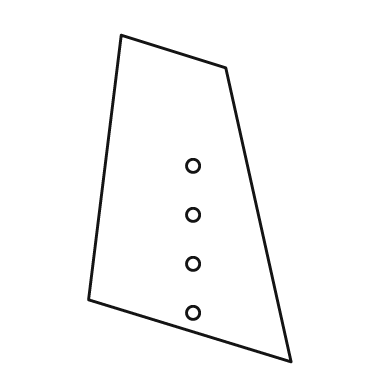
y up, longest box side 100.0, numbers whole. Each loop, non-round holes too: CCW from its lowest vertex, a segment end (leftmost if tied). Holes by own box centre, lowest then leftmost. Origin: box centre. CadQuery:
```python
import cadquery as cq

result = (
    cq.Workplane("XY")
    .moveTo(31.0, -50.0)
    .lineTo(11.0, 40.0)
    .lineTo(-21.0, 50.0)
    .lineTo(-31.0, -31.0)
    .close()
    .moveTo(1.0, -35.0)
    .circle(2.0)
    .moveTo(1.0, -20.0)
    .circle(2.0)
    .moveTo(1.0, -5.0)
    .circle(2.0)
    .moveTo(1.0, 10.0)
    .circle(2.0)
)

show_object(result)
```